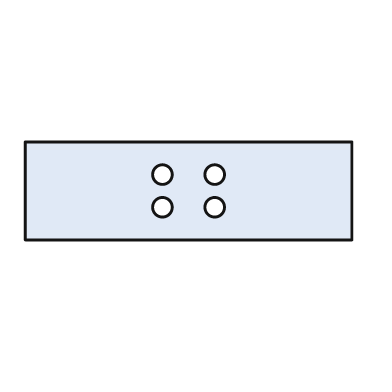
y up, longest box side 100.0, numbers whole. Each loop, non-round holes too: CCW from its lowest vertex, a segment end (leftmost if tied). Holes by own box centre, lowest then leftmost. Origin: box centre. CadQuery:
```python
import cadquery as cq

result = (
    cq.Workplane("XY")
    .moveTo(-50.0, -15.0)
    .lineTo(50.0, -15.0)
    .lineTo(50.0, 15.0)
    .lineTo(-50.0, 15.0)
    .close()
    .moveTo(-8.0, -5.0)
    .circle(3.0)
    .moveTo(8.0, -5.0)
    .circle(3.0)
    .moveTo(-8.0, 5.0)
    .circle(3.0)
    .moveTo(8.0, 5.0)
    .circle(3.0)
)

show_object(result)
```